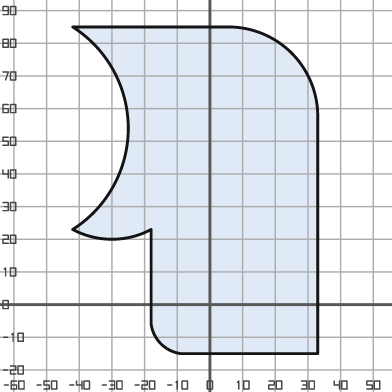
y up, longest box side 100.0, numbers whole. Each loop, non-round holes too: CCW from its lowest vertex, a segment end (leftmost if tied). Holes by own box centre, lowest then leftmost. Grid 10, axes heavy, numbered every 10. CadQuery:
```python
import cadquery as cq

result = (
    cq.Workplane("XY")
    .moveTo(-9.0, -15.0)
    .lineTo(33.0, -15.0)
    .lineTo(33.0, 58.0)
    .threePointArc((25.0, 77.0), (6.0, 85.0))
    .lineTo(-42.0, 85.0)
    .threePointArc((-25.0, 54.0), (-42.0, 23.0))
    .threePointArc((-30.0, 20.0), (-18.0, 23.0))
    .lineTo(-18.0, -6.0)
    .threePointArc((-15.0, -12.0), (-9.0, -15.0))
    .close()
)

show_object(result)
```